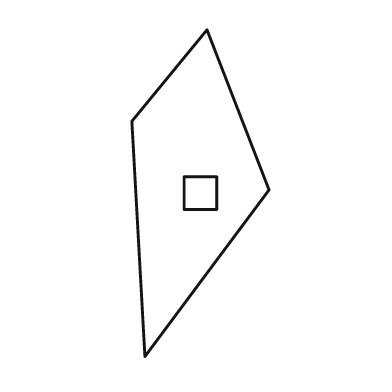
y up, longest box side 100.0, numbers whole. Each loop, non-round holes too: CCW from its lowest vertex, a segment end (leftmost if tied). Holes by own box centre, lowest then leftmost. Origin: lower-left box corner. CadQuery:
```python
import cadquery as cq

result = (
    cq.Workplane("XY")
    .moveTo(4.0, 0.0)
    .lineTo(42.0, 51.0)
    .lineTo(23.0, 100.0)
    .lineTo(0.0, 72.0)
    .close()
    .moveTo(16.0, 45.0)
    .lineTo(26.0, 45.0)
    .lineTo(26.0, 55.0)
    .lineTo(16.0, 55.0)
    .close()
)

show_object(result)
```